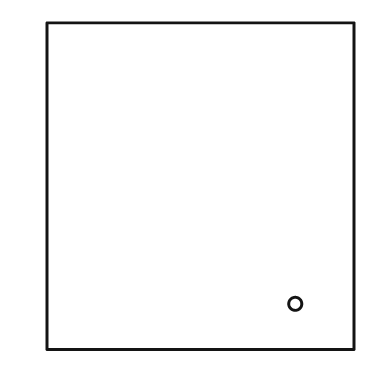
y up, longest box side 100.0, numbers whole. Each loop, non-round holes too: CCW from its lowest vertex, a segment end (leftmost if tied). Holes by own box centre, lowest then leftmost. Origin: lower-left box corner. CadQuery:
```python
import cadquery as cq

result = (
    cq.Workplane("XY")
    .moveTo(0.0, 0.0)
    .lineTo(94.0, 0.0)
    .lineTo(94.0, 100.0)
    .lineTo(0.0, 100.0)
    .close()
    .moveTo(76.0, 14.0)
    .circle(2.0)
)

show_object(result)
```